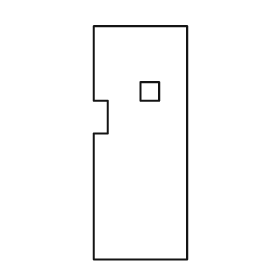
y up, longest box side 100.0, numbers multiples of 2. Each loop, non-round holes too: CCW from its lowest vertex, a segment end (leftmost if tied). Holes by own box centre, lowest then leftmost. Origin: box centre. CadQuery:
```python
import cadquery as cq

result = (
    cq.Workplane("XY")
    .moveTo(-20.0, -50.0)
    .lineTo(20.0, -50.0)
    .lineTo(20.0, 50.0)
    .lineTo(-20.0, 50.0)
    .lineTo(-20.0, 18.0)
    .lineTo(-14.0, 18.0)
    .lineTo(-14.0, 4.0)
    .lineTo(-20.0, 4.0)
    .close()
    .moveTo(0.0, 18.0)
    .lineTo(8.0, 18.0)
    .lineTo(8.0, 26.0)
    .lineTo(0.0, 26.0)
    .close()
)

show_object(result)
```